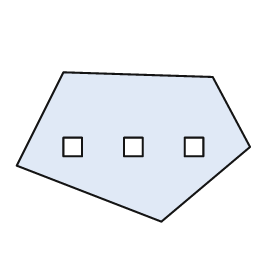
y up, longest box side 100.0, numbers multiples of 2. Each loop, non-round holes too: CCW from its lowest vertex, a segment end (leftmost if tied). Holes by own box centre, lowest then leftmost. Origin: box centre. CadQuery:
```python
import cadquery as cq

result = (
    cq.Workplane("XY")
    .moveTo(12.0, -32.0)
    .lineTo(50.0, 0.0)
    .lineTo(34.0, 30.0)
    .lineTo(-30.0, 32.0)
    .lineTo(-50.0, -8.0)
    .close()
    .moveTo(-30.0, -4.0)
    .lineTo(-22.0, -4.0)
    .lineTo(-22.0, 4.0)
    .lineTo(-30.0, 4.0)
    .close()
    .moveTo(-4.0, -4.0)
    .lineTo(4.0, -4.0)
    .lineTo(4.0, 4.0)
    .lineTo(-4.0, 4.0)
    .close()
    .moveTo(22.0, -4.0)
    .lineTo(30.0, -4.0)
    .lineTo(30.0, 4.0)
    .lineTo(22.0, 4.0)
    .close()
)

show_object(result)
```